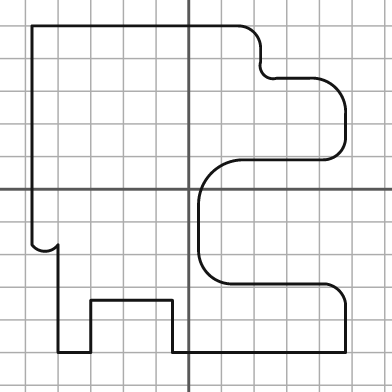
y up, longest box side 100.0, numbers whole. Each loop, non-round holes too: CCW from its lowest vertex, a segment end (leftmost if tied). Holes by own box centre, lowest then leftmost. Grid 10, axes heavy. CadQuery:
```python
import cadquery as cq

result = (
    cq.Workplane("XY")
    .moveTo(-40.0, -50.0)
    .lineTo(-30.0, -50.0)
    .lineTo(-30.0, -34.0)
    .lineTo(-5.0, -34.0)
    .lineTo(-5.0, -50.0)
    .lineTo(48.0, -50.0)
    .lineTo(48.0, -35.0)
    .threePointArc((46.0, -31.0), (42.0, -29.0))
    .lineTo(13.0, -29.0)
    .threePointArc((6.0, -26.0), (3.0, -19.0))
    .lineTo(3.0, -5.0)
    .threePointArc((7.0, 5.0), (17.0, 9.0))
    .lineTo(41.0, 9.0)
    .threePointArc((46.0, 11.0), (48.0, 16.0))
    .lineTo(48.0, 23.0)
    .threePointArc((45.0, 31.0), (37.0, 34.0))
    .lineTo(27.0, 34.0)
    .threePointArc((23.0, 35.0), (22.0, 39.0))
    .lineTo(22.0, 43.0)
    .threePointArc((20.0, 48.0), (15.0, 50.0))
    .lineTo(-48.0, 50.0)
    .lineTo(-48.0, -17.0)
    .threePointArc((-44.0, -19.0), (-40.0, -17.0))
    .close()
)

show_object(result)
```